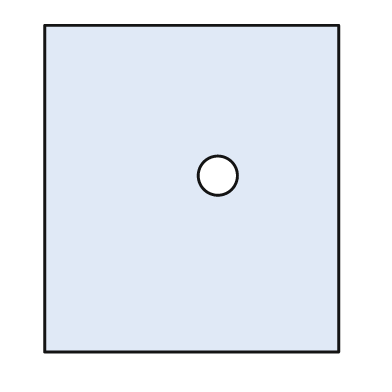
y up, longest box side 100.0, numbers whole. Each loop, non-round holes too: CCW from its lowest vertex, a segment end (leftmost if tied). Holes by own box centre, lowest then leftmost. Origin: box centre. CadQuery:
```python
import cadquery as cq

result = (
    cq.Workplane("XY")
    .moveTo(-45.0, -50.0)
    .lineTo(45.0, -50.0)
    .lineTo(45.0, 50.0)
    .lineTo(-45.0, 50.0)
    .close()
    .moveTo(8.0, 4.0)
    .circle(6.0)
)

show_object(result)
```